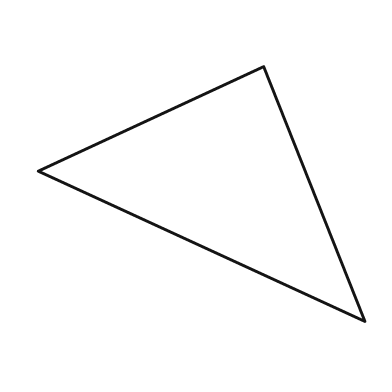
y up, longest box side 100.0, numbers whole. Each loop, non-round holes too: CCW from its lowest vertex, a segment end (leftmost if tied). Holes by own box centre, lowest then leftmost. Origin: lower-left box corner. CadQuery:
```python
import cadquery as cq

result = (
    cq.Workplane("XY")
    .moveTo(100.0, 0.0)
    .lineTo(69.0, 78.0)
    .lineTo(0.0, 46.0)
    .close()
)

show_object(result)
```